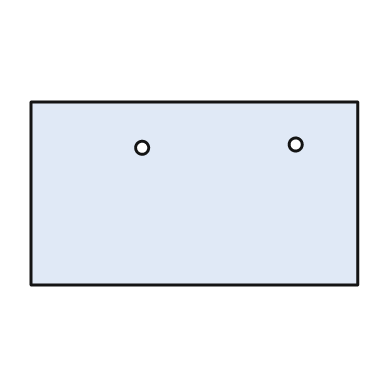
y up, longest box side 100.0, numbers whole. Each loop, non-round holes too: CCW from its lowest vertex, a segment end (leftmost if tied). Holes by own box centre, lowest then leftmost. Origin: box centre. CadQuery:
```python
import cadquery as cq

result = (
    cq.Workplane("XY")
    .moveTo(-50.0, -28.0)
    .lineTo(50.0, -28.0)
    .lineTo(50.0, 28.0)
    .lineTo(-50.0, 28.0)
    .close()
    .moveTo(-16.0, 14.0)
    .circle(2.0)
    .moveTo(31.0, 15.0)
    .circle(2.0)
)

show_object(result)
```